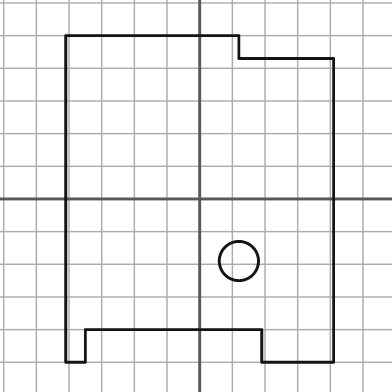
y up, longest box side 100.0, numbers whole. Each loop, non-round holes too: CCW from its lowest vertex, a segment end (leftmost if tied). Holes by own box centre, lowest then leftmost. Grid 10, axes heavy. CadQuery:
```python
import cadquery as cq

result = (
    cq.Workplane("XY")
    .moveTo(-41.0, -50.0)
    .lineTo(-35.0, -50.0)
    .lineTo(-35.0, -40.0)
    .lineTo(19.0, -40.0)
    .lineTo(19.0, -50.0)
    .lineTo(41.0, -50.0)
    .lineTo(41.0, 43.0)
    .lineTo(12.0, 43.0)
    .lineTo(12.0, 50.0)
    .lineTo(-41.0, 50.0)
    .close()
    .moveTo(12.0, -19.0)
    .circle(6.0)
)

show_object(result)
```